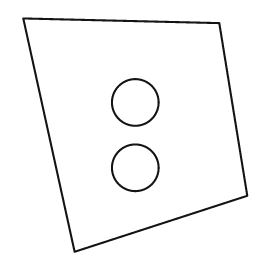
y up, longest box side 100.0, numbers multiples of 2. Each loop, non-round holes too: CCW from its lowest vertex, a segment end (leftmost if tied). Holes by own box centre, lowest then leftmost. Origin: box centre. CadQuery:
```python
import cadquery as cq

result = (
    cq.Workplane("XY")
    .moveTo(-26.0, -50.0)
    .lineTo(48.0, -26.0)
    .lineTo(36.0, 48.0)
    .lineTo(-48.0, 50.0)
    .close()
    .moveTo(0.0, -14.0)
    .circle(10.0)
    .moveTo(0.0, 14.0)
    .circle(10.0)
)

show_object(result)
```